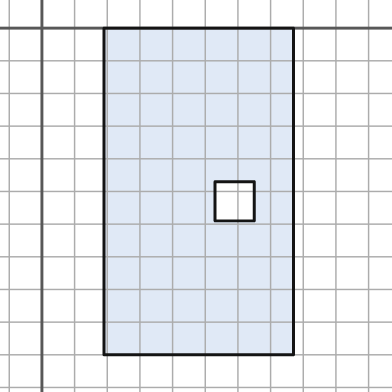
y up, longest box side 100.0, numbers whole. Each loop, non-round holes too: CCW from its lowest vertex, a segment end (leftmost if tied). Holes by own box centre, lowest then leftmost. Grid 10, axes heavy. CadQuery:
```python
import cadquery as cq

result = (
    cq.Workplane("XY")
    .moveTo(19.0, -100.0)
    .lineTo(77.0, -100.0)
    .lineTo(77.0, 0.0)
    .lineTo(19.0, 0.0)
    .close()
    .moveTo(53.0, -59.0)
    .lineTo(65.0, -59.0)
    .lineTo(65.0, -47.0)
    .lineTo(53.0, -47.0)
    .close()
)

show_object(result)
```